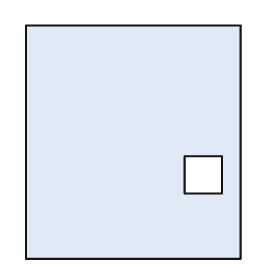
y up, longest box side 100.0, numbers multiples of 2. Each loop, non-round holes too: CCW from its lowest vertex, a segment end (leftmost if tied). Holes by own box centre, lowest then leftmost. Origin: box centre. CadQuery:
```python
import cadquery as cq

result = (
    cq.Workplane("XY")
    .moveTo(-46.0, -50.0)
    .lineTo(46.0, -50.0)
    .lineTo(46.0, 50.0)
    .lineTo(-46.0, 50.0)
    .close()
    .moveTo(22.0, -22.0)
    .lineTo(38.0, -22.0)
    .lineTo(38.0, -6.0)
    .lineTo(22.0, -6.0)
    .close()
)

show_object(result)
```